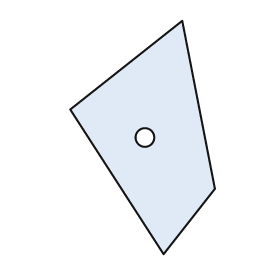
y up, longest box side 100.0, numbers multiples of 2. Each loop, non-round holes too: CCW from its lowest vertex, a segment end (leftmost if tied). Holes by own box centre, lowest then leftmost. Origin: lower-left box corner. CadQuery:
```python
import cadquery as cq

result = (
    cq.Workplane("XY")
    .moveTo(40.0, 0.0)
    .lineTo(62.0, 28.0)
    .lineTo(48.0, 100.0)
    .lineTo(0.0, 62.0)
    .close()
    .moveTo(32.0, 50.0)
    .circle(4.0)
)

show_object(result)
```